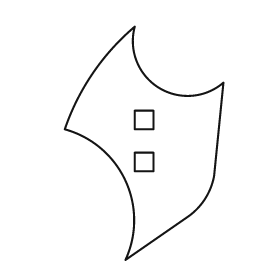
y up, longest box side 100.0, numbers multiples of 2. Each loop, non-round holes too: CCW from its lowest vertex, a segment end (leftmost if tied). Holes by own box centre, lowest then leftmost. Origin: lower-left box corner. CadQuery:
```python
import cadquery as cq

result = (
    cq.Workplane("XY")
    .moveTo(26.0, 0.0)
    .lineTo(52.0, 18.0)
    .threePointArc((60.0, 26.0), (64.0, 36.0))
    .lineTo(68.0, 76.0)
    .threePointArc((40.0, 74.0), (30.0, 100.0))
    .threePointArc((12.0, 80.0), (0.0, 56.0))
    .threePointArc((26.0, 34.0), (26.0, 0.0))
    .close()
    .moveTo(30.0, 38.0)
    .lineTo(38.0, 38.0)
    .lineTo(38.0, 46.0)
    .lineTo(30.0, 46.0)
    .close()
    .moveTo(30.0, 56.0)
    .lineTo(38.0, 56.0)
    .lineTo(38.0, 64.0)
    .lineTo(30.0, 64.0)
    .close()
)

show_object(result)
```